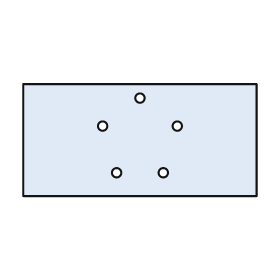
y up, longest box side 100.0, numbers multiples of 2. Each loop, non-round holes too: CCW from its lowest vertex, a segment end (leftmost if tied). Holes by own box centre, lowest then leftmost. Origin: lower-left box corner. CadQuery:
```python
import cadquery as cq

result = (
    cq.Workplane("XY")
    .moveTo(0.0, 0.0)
    .lineTo(100.0, 0.0)
    .lineTo(100.0, 48.0)
    .lineTo(0.0, 48.0)
    .close()
    .moveTo(40.0, 10.0)
    .circle(2.0)
    .moveTo(60.0, 10.0)
    .circle(2.0)
    .moveTo(34.0, 30.0)
    .circle(2.0)
    .moveTo(66.0, 30.0)
    .circle(2.0)
    .moveTo(50.0, 42.0)
    .circle(2.0)
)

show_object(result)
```